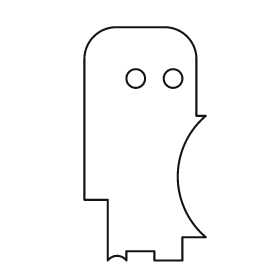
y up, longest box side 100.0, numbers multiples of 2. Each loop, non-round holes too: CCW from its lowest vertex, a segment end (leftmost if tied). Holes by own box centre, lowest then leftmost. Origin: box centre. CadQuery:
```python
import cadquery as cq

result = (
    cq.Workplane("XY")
    .moveTo(-16.0, -50.0)
    .threePointArc((-12.0, -48.0), (-8.0, -50.0))
    .lineTo(-8.0, -46.0)
    .lineTo(4.0, -46.0)
    .lineTo(4.0, -50.0)
    .lineTo(16.0, -50.0)
    .lineTo(16.0, -40.0)
    .lineTo(26.0, -40.0)
    .threePointArc((14.0, -14.0), (26.0, 12.0))
    .lineTo(22.0, 12.0)
    .lineTo(22.0, 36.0)
    .threePointArc((18.0, 46.0), (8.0, 50.0))
    .lineTo(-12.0, 50.0)
    .threePointArc((-22.0, 46.0), (-26.0, 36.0))
    .lineTo(-26.0, -24.0)
    .lineTo(-16.0, -24.0)
    .close()
    .moveTo(-4.0, 28.0)
    .circle(4.0)
    .moveTo(12.0, 28.0)
    .circle(4.0)
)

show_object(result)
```